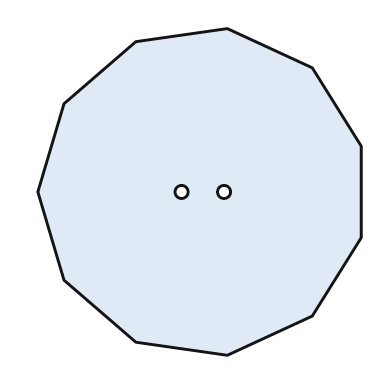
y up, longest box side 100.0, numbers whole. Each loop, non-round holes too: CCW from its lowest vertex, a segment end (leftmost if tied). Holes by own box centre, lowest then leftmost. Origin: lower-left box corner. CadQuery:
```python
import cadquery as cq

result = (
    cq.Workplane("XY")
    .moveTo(58.0, 0.0)
    .lineTo(84.0, 12.0)
    .lineTo(99.0, 36.0)
    .lineTo(99.0, 64.0)
    .lineTo(84.0, 88.0)
    .lineTo(58.0, 100.0)
    .lineTo(30.0, 96.0)
    .lineTo(8.0, 77.0)
    .lineTo(0.0, 50.0)
    .lineTo(8.0, 23.0)
    .lineTo(30.0, 4.0)
    .close()
    .moveTo(44.0, 50.0)
    .circle(2.0)
    .moveTo(57.0, 50.0)
    .circle(2.0)
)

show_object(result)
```